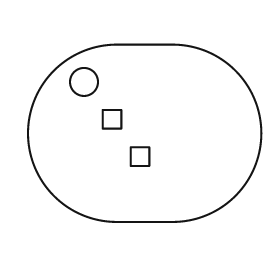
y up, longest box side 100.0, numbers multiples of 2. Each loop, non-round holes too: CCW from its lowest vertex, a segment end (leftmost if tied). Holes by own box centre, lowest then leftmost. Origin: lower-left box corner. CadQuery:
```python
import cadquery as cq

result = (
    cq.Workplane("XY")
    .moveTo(38.0, 0.0)
    .lineTo(62.0, 0.0)
    .threePointArc((100.0, 38.0), (62.0, 76.0))
    .lineTo(38.0, 76.0)
    .threePointArc((0.0, 38.0), (38.0, 0.0))
    .close()
    .moveTo(44.0, 24.0)
    .lineTo(52.0, 24.0)
    .lineTo(52.0, 32.0)
    .lineTo(44.0, 32.0)
    .close()
    .moveTo(32.0, 40.0)
    .lineTo(40.0, 40.0)
    .lineTo(40.0, 48.0)
    .lineTo(32.0, 48.0)
    .close()
    .moveTo(24.0, 60.0)
    .circle(6.0)
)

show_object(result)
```